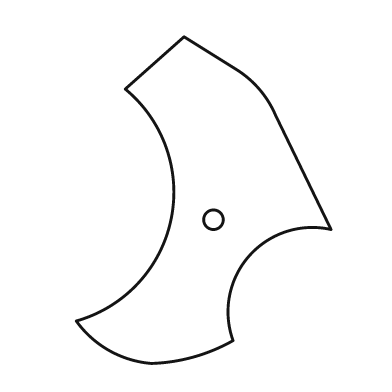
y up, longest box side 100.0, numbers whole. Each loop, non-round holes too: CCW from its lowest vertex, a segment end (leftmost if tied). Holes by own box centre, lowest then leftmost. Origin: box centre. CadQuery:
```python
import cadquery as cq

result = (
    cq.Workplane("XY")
    .moveTo(-16.0, -50.0)
    .threePointArc((-3.0, -48.0), (9.0, -43.0))
    .threePointArc((14.0, -17.0), (39.0, -9.0))
    .lineTo(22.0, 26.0)
    .threePointArc((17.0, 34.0), (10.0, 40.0))
    .lineTo(-6.0, 50.0)
    .lineTo(-24.0, 34.0)
    .threePointArc((-10.0, -6.0), (-39.0, -37.0))
    .threePointArc((-29.0, -46.0), (-16.0, -50.0))
    .close()
    .moveTo(3.0, -6.0)
    .circle(3.0)
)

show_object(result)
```